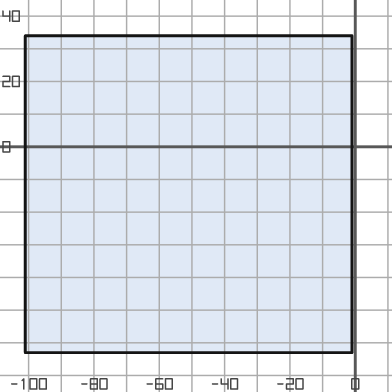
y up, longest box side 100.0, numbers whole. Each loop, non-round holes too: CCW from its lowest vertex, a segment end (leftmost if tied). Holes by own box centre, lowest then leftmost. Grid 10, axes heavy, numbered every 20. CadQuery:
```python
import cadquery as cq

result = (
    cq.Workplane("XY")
    .moveTo(-101.0, -63.0)
    .lineTo(-1.0, -63.0)
    .lineTo(-1.0, 34.0)
    .lineTo(-101.0, 34.0)
    .close()
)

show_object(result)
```